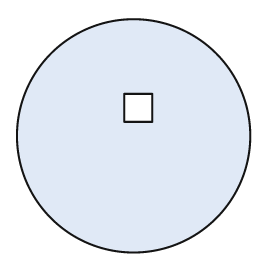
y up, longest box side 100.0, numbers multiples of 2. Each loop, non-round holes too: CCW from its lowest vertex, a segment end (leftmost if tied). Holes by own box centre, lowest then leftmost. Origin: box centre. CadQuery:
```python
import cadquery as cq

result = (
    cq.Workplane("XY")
    .moveTo(0.0, 0.0)
    .circle(50.0)
    .moveTo(-4.0, 6.0)
    .lineTo(8.0, 6.0)
    .lineTo(8.0, 18.0)
    .lineTo(-4.0, 18.0)
    .close()
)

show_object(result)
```